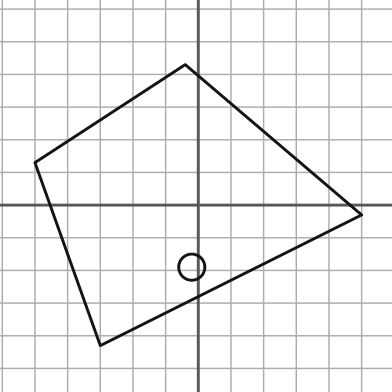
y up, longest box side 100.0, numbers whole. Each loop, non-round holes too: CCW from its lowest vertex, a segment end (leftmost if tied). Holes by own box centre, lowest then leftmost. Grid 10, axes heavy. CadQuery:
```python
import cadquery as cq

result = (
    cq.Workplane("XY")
    .moveTo(-30.0, -43.0)
    .lineTo(50.0, -3.0)
    .lineTo(-4.0, 43.0)
    .lineTo(-50.0, 13.0)
    .close()
    .moveTo(-2.0, -19.0)
    .circle(4.0)
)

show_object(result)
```